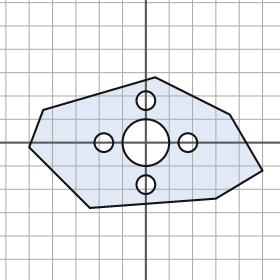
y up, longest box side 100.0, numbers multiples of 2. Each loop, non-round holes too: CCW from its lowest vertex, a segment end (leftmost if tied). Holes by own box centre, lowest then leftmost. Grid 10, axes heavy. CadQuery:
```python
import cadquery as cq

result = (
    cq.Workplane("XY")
    .moveTo(-24.0, -28.0)
    .lineTo(30.0, -24.0)
    .lineTo(50.0, -12.0)
    .lineTo(36.0, 12.0)
    .lineTo(4.0, 28.0)
    .lineTo(-44.0, 14.0)
    .lineTo(-50.0, -2.0)
    .close()
    .moveTo(0.0, -18.0)
    .circle(4.0)
    .moveTo(-18.0, 0.0)
    .circle(4.0)
    .moveTo(0.0, 0.0)
    .circle(10.0)
    .moveTo(18.0, 0.0)
    .circle(4.0)
    .moveTo(0.0, 18.0)
    .circle(4.0)
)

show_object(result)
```